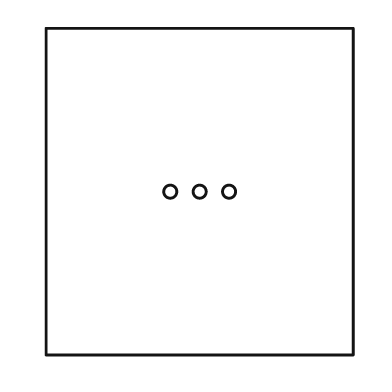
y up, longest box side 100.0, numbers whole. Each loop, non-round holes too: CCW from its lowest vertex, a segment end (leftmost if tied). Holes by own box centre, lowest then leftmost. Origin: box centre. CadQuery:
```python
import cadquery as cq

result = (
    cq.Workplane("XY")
    .moveTo(-47.0, -50.0)
    .lineTo(47.0, -50.0)
    .lineTo(47.0, 50.0)
    .lineTo(-47.0, 50.0)
    .close()
    .moveTo(-9.0, 0.0)
    .circle(2.0)
    .moveTo(0.0, 0.0)
    .circle(2.0)
    .moveTo(9.0, 0.0)
    .circle(2.0)
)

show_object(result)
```